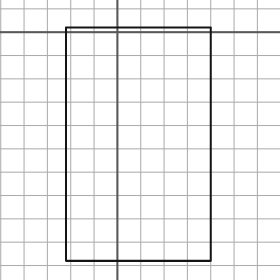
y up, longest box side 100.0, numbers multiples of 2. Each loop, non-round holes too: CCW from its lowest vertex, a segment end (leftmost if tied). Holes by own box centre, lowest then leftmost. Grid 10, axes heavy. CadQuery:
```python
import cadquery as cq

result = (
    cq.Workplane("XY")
    .moveTo(-22.0, -98.0)
    .lineTo(40.0, -98.0)
    .lineTo(40.0, 2.0)
    .lineTo(-22.0, 2.0)
    .close()
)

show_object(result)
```